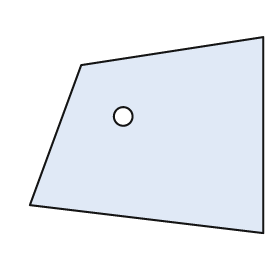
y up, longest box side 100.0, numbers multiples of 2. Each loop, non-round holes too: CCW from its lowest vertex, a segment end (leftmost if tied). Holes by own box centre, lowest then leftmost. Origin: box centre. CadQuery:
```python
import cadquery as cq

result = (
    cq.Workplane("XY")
    .moveTo(50.0, -42.0)
    .lineTo(50.0, 42.0)
    .lineTo(-28.0, 30.0)
    .lineTo(-50.0, -30.0)
    .close()
    .moveTo(-10.0, 8.0)
    .circle(4.0)
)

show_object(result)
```